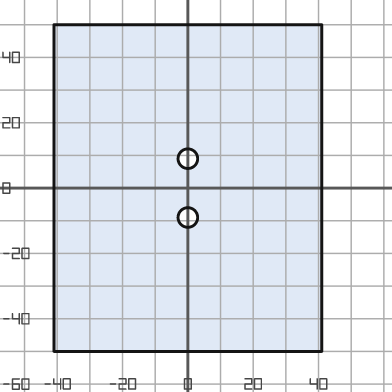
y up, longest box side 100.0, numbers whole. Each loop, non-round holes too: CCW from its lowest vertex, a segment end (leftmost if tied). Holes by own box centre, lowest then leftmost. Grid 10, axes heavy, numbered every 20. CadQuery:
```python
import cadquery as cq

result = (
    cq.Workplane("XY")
    .moveTo(-41.0, -50.0)
    .lineTo(41.0, -50.0)
    .lineTo(41.0, 50.0)
    .lineTo(-41.0, 50.0)
    .close()
    .moveTo(0.0, -9.0)
    .circle(3.0)
    .moveTo(0.0, 9.0)
    .circle(3.0)
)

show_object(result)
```